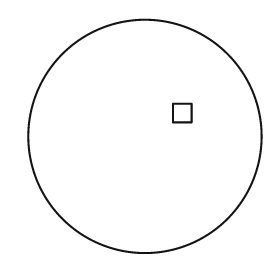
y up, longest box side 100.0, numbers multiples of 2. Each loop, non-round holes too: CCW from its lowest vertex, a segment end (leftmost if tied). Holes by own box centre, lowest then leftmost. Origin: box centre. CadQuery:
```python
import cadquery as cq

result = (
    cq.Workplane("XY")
    .moveTo(0.0, 0.0)
    .circle(50.0)
    .moveTo(12.0, 6.0)
    .lineTo(20.0, 6.0)
    .lineTo(20.0, 14.0)
    .lineTo(12.0, 14.0)
    .close()
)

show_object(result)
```